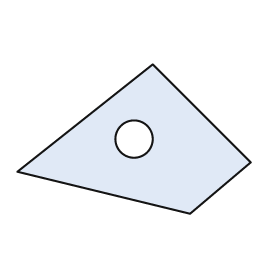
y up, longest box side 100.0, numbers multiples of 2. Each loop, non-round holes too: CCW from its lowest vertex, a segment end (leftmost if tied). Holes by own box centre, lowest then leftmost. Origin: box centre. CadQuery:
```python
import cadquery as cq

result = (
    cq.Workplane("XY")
    .moveTo(24.0, -32.0)
    .lineTo(50.0, -10.0)
    .lineTo(8.0, 32.0)
    .lineTo(-50.0, -14.0)
    .close()
    .moveTo(0.0, 0.0)
    .circle(8.0)
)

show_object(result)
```